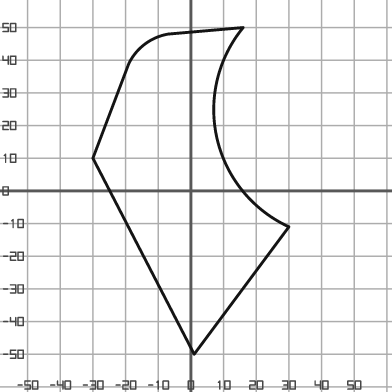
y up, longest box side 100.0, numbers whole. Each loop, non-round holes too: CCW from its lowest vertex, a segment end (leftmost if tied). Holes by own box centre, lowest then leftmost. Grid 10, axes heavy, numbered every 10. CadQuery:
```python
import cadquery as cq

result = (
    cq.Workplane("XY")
    .moveTo(1.0, -50.0)
    .lineTo(30.0, -11.0)
    .threePointArc((8.0, 16.0), (16.0, 50.0))
    .lineTo(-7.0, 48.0)
    .threePointArc((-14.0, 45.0), (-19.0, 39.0))
    .lineTo(-30.0, 10.0)
    .close()
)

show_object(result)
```